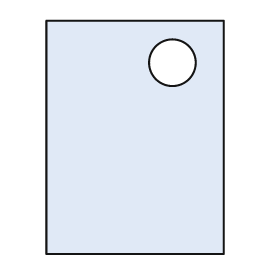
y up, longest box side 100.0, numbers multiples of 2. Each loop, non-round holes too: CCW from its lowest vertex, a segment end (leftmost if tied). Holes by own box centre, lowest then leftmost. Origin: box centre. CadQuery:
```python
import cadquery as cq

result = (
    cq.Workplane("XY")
    .moveTo(-38.0, -50.0)
    .lineTo(38.0, -50.0)
    .lineTo(38.0, 50.0)
    .lineTo(-38.0, 50.0)
    .close()
    .moveTo(16.0, 32.0)
    .circle(10.0)
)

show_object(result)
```